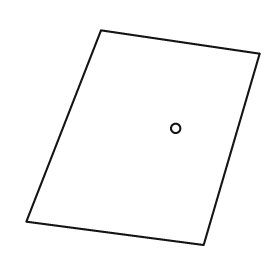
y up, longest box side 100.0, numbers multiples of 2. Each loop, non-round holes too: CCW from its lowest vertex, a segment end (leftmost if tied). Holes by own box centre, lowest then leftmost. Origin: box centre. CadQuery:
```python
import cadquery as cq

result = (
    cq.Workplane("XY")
    .moveTo(26.0, -46.0)
    .lineTo(50.0, 36.0)
    .lineTo(-18.0, 46.0)
    .lineTo(-50.0, -36.0)
    .close()
    .moveTo(14.0, 4.0)
    .circle(2.0)
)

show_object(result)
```